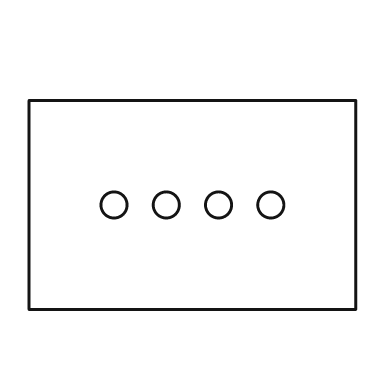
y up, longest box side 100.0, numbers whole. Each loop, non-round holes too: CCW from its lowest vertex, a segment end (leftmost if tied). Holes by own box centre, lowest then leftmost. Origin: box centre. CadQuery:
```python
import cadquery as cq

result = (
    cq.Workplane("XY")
    .moveTo(-50.0, -32.0)
    .lineTo(50.0, -32.0)
    .lineTo(50.0, 32.0)
    .lineTo(-50.0, 32.0)
    .close()
    .moveTo(-24.0, 0.0)
    .circle(4.0)
    .moveTo(-8.0, 0.0)
    .circle(4.0)
    .moveTo(8.0, 0.0)
    .circle(4.0)
    .moveTo(24.0, 0.0)
    .circle(4.0)
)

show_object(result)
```